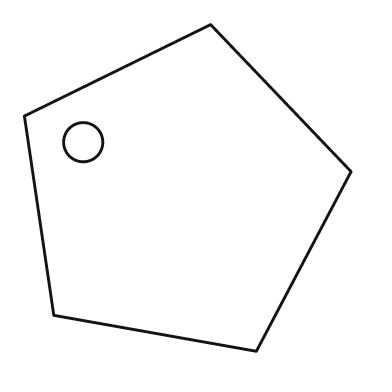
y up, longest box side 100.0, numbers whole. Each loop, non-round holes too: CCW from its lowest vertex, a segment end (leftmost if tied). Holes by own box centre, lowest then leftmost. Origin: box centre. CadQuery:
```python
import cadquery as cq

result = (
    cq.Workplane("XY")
    .moveTo(21.0, -50.0)
    .lineTo(50.0, 5.0)
    .lineTo(7.0, 50.0)
    .lineTo(-50.0, 22.0)
    .lineTo(-41.0, -39.0)
    .close()
    .moveTo(-32.0, 14.0)
    .circle(6.0)
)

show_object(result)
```